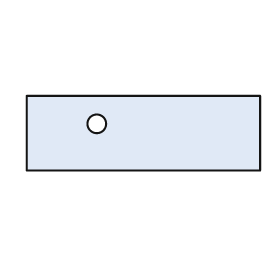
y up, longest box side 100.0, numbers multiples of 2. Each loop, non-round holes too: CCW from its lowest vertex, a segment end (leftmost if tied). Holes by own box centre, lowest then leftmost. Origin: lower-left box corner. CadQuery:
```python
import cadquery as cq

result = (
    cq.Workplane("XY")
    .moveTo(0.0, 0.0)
    .lineTo(100.0, 0.0)
    .lineTo(100.0, 32.0)
    .lineTo(0.0, 32.0)
    .close()
    .moveTo(30.0, 20.0)
    .circle(4.0)
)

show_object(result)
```